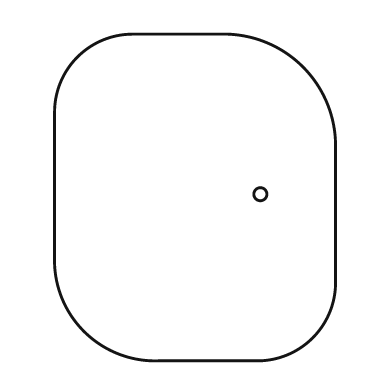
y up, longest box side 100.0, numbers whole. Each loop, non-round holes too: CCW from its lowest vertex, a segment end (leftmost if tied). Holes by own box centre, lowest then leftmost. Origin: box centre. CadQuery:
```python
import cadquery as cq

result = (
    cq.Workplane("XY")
    .moveTo(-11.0, -50.0)
    .lineTo(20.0, -50.0)
    .threePointArc((36.0, -43.0), (43.0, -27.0))
    .lineTo(43.0, 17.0)
    .threePointArc((33.0, 40.0), (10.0, 50.0))
    .lineTo(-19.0, 50.0)
    .threePointArc((-36.0, 43.0), (-43.0, 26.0))
    .lineTo(-43.0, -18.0)
    .threePointArc((-34.0, -41.0), (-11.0, -50.0))
    .close()
    .moveTo(20.0, 1.0)
    .circle(2.0)
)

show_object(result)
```